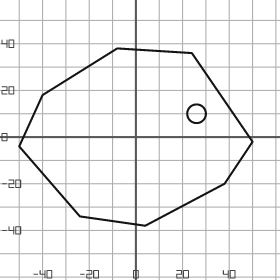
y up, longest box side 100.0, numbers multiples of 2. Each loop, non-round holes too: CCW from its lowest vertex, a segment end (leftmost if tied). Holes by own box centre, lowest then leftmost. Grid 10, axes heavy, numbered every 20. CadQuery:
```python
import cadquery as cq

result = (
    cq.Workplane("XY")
    .moveTo(4.0, -38.0)
    .lineTo(38.0, -20.0)
    .lineTo(50.0, -2.0)
    .lineTo(24.0, 36.0)
    .lineTo(-8.0, 38.0)
    .lineTo(-40.0, 18.0)
    .lineTo(-50.0, -4.0)
    .lineTo(-24.0, -34.0)
    .close()
    .moveTo(26.0, 10.0)
    .circle(4.0)
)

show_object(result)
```